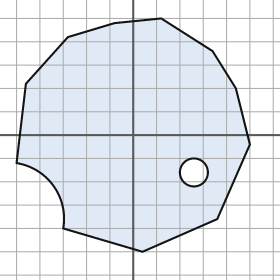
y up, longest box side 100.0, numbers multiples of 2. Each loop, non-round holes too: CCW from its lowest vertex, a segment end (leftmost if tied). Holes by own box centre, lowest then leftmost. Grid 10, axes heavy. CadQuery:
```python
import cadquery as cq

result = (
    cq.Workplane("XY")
    .moveTo(4.0, -50.0)
    .lineTo(36.0, -36.0)
    .lineTo(50.0, -4.0)
    .lineTo(44.0, 20.0)
    .lineTo(34.0, 36.0)
    .lineTo(12.0, 50.0)
    .lineTo(-8.0, 48.0)
    .lineTo(-28.0, 42.0)
    .lineTo(-46.0, 22.0)
    .lineTo(-50.0, -12.0)
    .threePointArc((-34.0, -22.0), (-30.0, -40.0))
    .close()
    .moveTo(26.0, -16.0)
    .circle(6.0)
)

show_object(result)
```